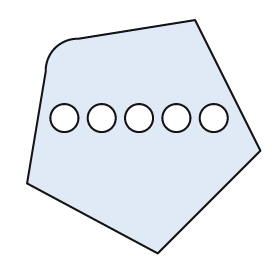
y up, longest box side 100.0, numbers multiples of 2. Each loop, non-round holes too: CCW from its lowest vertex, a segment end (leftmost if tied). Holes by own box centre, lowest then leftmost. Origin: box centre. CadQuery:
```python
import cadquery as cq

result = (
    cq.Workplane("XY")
    .moveTo(6.0, -50.0)
    .lineTo(50.0, -6.0)
    .lineTo(22.0, 50.0)
    .lineTo(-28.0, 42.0)
    .threePointArc((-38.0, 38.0), (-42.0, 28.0))
    .lineTo(-50.0, -20.0)
    .close()
    .moveTo(-34.0, 8.0)
    .circle(6.0)
    .moveTo(-18.0, 8.0)
    .circle(6.0)
    .moveTo(-2.0, 8.0)
    .circle(6.0)
    .moveTo(14.0, 8.0)
    .circle(6.0)
    .moveTo(30.0, 8.0)
    .circle(6.0)
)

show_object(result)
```